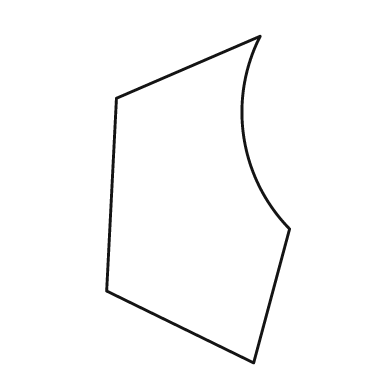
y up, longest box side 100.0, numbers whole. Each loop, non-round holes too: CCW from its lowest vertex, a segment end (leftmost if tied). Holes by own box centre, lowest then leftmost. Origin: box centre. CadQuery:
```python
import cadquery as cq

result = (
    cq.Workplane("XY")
    .moveTo(17.0, -50.0)
    .lineTo(28.0, -9.0)
    .threePointArc((14.0, 19.0), (19.0, 50.0))
    .lineTo(-25.0, 31.0)
    .lineTo(-28.0, -28.0)
    .close()
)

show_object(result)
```